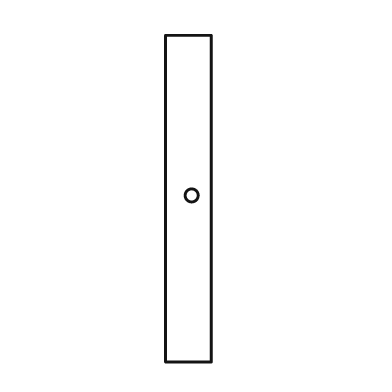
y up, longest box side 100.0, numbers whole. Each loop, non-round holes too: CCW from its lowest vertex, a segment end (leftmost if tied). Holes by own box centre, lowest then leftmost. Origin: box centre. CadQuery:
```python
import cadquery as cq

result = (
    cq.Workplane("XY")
    .moveTo(-7.0, -50.0)
    .lineTo(7.0, -50.0)
    .lineTo(7.0, 50.0)
    .lineTo(-7.0, 50.0)
    .close()
    .moveTo(1.0, 1.0)
    .circle(2.0)
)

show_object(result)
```